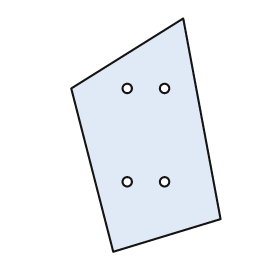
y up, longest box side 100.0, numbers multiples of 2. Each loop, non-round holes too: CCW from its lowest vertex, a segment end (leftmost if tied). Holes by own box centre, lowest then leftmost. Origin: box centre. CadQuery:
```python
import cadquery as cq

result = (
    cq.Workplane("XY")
    .moveTo(-14.0, -50.0)
    .lineTo(32.0, -36.0)
    .lineTo(16.0, 50.0)
    .lineTo(-32.0, 20.0)
    .close()
    .moveTo(-8.0, -20.0)
    .circle(2.0)
    .moveTo(8.0, -20.0)
    .circle(2.0)
    .moveTo(-8.0, 20.0)
    .circle(2.0)
    .moveTo(8.0, 20.0)
    .circle(2.0)
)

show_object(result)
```